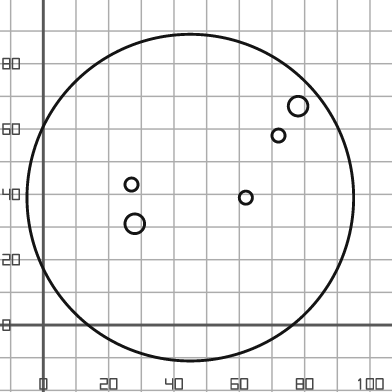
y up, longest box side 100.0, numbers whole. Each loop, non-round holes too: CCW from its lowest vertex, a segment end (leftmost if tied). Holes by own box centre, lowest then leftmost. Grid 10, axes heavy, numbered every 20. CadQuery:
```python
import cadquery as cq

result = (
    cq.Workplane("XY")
    .moveTo(45.0, 39.0)
    .circle(50.0)
    .moveTo(28.0, 31.0)
    .circle(3.0)
    .moveTo(62.0, 39.0)
    .circle(2.0)
    .moveTo(27.0, 43.0)
    .circle(2.0)
    .moveTo(72.0, 58.0)
    .circle(2.0)
    .moveTo(78.0, 67.0)
    .circle(3.0)
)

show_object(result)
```